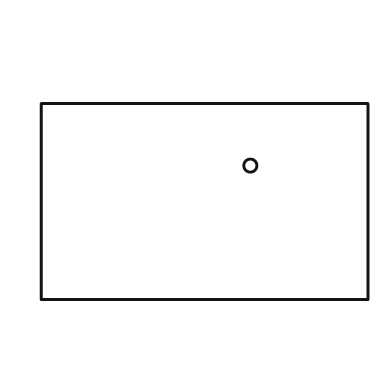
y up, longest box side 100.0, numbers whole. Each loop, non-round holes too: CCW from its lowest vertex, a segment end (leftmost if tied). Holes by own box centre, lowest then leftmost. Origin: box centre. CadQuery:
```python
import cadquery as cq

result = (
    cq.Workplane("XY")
    .moveTo(-50.0, -30.0)
    .lineTo(50.0, -30.0)
    .lineTo(50.0, 30.0)
    .lineTo(-50.0, 30.0)
    .close()
    .moveTo(14.0, 11.0)
    .circle(2.0)
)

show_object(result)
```